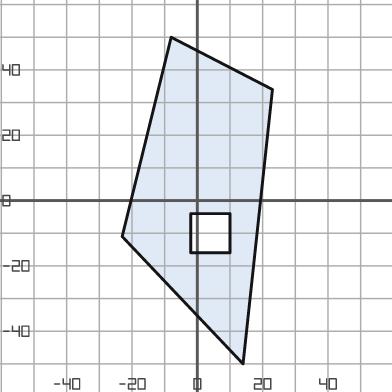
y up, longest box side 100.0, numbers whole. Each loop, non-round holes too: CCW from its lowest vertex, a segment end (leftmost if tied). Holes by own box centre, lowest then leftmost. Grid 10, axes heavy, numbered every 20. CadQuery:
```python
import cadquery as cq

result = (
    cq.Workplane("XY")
    .moveTo(14.0, -50.0)
    .lineTo(23.0, 34.0)
    .lineTo(-8.0, 50.0)
    .lineTo(-23.0, -11.0)
    .close()
    .moveTo(-2.0, -16.0)
    .lineTo(10.0, -16.0)
    .lineTo(10.0, -4.0)
    .lineTo(-2.0, -4.0)
    .close()
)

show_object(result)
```